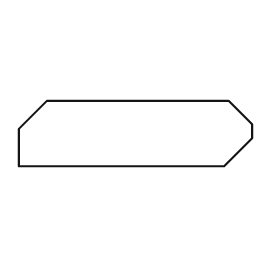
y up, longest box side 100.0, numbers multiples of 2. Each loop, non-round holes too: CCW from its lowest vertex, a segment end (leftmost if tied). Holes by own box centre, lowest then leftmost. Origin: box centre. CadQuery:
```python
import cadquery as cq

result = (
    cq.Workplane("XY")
    .moveTo(-50.0, -14.0)
    .lineTo(38.0, -14.0)
    .lineTo(50.0, -2.0)
    .lineTo(50.0, 4.0)
    .lineTo(40.0, 14.0)
    .lineTo(-38.0, 14.0)
    .lineTo(-50.0, 2.0)
    .close()
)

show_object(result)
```